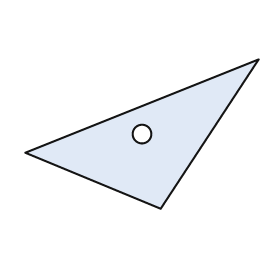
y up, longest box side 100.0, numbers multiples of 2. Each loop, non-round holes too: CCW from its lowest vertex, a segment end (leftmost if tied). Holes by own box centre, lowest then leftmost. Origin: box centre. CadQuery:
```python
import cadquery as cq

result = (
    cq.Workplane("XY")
    .moveTo(8.0, -32.0)
    .lineTo(50.0, 32.0)
    .lineTo(-50.0, -8.0)
    .close()
    .moveTo(0.0, 0.0)
    .circle(4.0)
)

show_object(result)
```